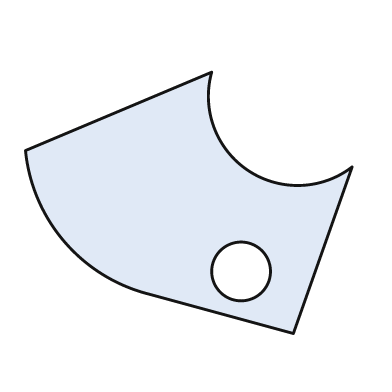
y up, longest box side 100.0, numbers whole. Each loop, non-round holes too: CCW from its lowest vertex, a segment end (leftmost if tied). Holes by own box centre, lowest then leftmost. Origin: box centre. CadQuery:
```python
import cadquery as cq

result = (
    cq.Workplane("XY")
    .moveTo(32.0, -40.0)
    .lineTo(50.0, 11.0)
    .threePointArc((18.0, 10.0), (7.0, 40.0))
    .lineTo(-50.0, 16.0)
    .threePointArc((-38.0, -12.0), (-12.0, -28.0))
    .close()
    .moveTo(16.0, -21.0)
    .circle(9.0)
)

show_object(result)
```